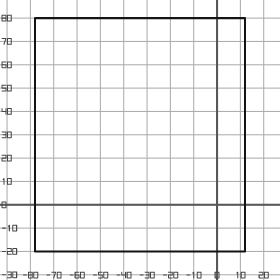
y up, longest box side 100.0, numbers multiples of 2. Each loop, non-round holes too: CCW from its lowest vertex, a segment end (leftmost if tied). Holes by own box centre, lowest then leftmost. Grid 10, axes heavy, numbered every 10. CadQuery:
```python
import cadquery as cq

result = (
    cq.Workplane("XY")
    .moveTo(-78.0, -20.0)
    .lineTo(12.0, -20.0)
    .lineTo(12.0, 80.0)
    .lineTo(-78.0, 80.0)
    .close()
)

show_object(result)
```